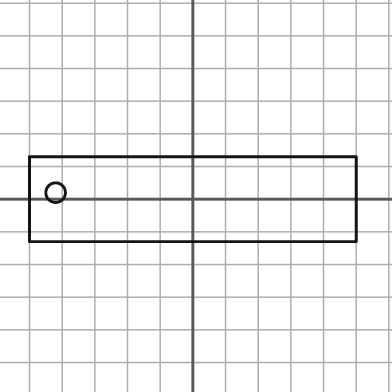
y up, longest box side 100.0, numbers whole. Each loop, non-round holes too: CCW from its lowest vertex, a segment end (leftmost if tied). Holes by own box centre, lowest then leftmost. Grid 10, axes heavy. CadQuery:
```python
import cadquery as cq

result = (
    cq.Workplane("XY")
    .moveTo(-50.0, -13.0)
    .lineTo(50.0, -13.0)
    .lineTo(50.0, 13.0)
    .lineTo(-50.0, 13.0)
    .close()
    .moveTo(-42.0, 2.0)
    .circle(3.0)
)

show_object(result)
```